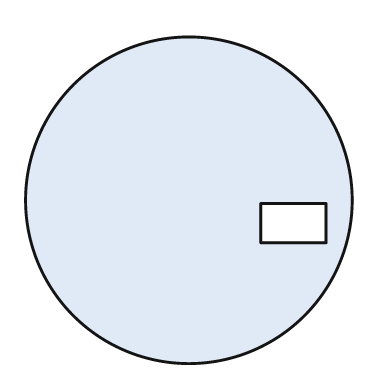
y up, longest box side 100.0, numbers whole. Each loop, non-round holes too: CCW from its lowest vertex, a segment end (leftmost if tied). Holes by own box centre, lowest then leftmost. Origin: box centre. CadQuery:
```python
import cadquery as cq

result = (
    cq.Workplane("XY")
    .moveTo(0.0, 0.0)
    .circle(50.0)
    .moveTo(22.0, -13.0)
    .lineTo(42.0, -13.0)
    .lineTo(42.0, -1.0)
    .lineTo(22.0, -1.0)
    .close()
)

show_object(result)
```